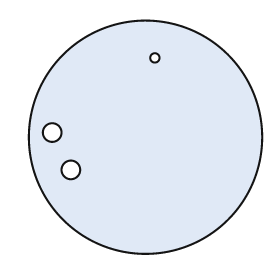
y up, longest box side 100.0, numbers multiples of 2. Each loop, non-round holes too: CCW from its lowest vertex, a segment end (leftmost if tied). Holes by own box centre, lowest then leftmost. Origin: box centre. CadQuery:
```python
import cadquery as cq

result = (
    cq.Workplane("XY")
    .moveTo(0.0, 0.0)
    .circle(50.0)
    .moveTo(-32.0, -14.0)
    .circle(4.0)
    .moveTo(-40.0, 2.0)
    .circle(4.0)
    .moveTo(4.0, 34.0)
    .circle(2.0)
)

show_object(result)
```